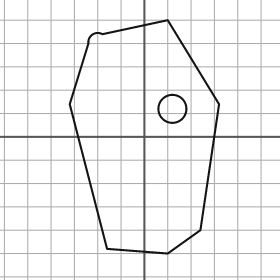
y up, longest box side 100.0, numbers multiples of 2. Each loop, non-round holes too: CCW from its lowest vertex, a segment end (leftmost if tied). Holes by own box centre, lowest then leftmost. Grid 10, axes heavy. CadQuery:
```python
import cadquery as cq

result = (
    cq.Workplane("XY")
    .moveTo(10.0, -50.0)
    .lineTo(24.0, -40.0)
    .lineTo(32.0, 14.0)
    .lineTo(10.0, 50.0)
    .lineTo(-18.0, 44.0)
    .threePointArc((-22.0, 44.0), (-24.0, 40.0))
    .lineTo(-32.0, 14.0)
    .lineTo(-16.0, -48.0)
    .close()
    .moveTo(12.0, 12.0)
    .circle(6.0)
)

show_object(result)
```